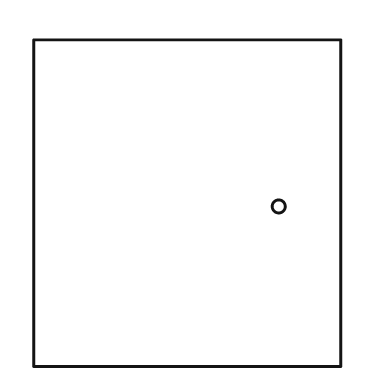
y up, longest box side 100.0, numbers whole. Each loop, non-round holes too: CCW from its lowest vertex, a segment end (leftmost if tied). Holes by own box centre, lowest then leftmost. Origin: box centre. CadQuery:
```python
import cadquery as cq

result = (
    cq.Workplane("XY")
    .moveTo(-47.0, -50.0)
    .lineTo(47.0, -50.0)
    .lineTo(47.0, 50.0)
    .lineTo(-47.0, 50.0)
    .close()
    .moveTo(28.0, -1.0)
    .circle(2.0)
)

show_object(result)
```